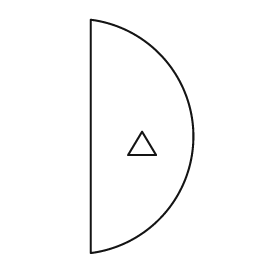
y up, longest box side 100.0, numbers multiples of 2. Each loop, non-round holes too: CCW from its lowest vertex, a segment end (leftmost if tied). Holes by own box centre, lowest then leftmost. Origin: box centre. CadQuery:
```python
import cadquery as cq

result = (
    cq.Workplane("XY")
    .moveTo(-22.0, -50.0)
    .threePointArc((22.0, 0.0), (-22.0, 50.0))
    .close()
    .moveTo(-6.0, -8.0)
    .lineTo(6.0, -8.0)
    .lineTo(0.0, 2.0)
    .close()
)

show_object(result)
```